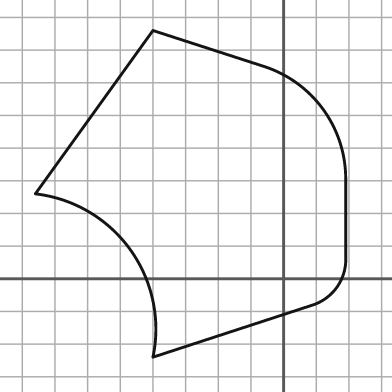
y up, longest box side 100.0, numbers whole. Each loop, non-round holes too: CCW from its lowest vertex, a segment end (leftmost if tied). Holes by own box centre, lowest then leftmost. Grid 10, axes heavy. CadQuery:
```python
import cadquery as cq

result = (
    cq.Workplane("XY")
    .moveTo(-40.0, -24.0)
    .lineTo(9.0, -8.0)
    .threePointArc((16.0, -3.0), (19.0, 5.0))
    .lineTo(19.0, 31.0)
    .threePointArc((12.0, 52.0), (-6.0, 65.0))
    .lineTo(-40.0, 76.0)
    .lineTo(-76.0, 26.0)
    .threePointArc((-47.0, 9.0), (-40.0, -24.0))
    .close()
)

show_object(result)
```